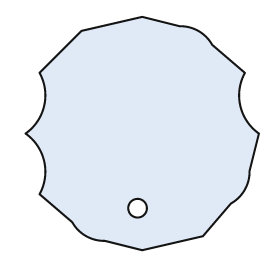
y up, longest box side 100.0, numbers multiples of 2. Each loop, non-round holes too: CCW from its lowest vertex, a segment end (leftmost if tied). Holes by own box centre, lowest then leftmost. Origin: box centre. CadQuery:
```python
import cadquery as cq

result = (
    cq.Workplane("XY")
    .moveTo(0.0, -50.0)
    .lineTo(26.0, -44.0)
    .lineTo(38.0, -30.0)
    .threePointArc((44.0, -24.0), (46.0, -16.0))
    .lineTo(50.0, 0.0)
    .threePointArc((42.0, 12.0), (44.0, 26.0))
    .lineTo(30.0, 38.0)
    .threePointArc((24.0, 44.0), (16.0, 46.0))
    .lineTo(0.0, 50.0)
    .lineTo(-26.0, 44.0)
    .lineTo(-44.0, 26.0)
    .threePointArc((-42.0, 12.0), (-50.0, 0.0))
    .threePointArc((-42.0, -12.0), (-44.0, -26.0))
    .lineTo(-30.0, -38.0)
    .threePointArc((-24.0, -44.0), (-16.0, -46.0))
    .close()
    .moveTo(-2.0, -32.0)
    .circle(4.0)
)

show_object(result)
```